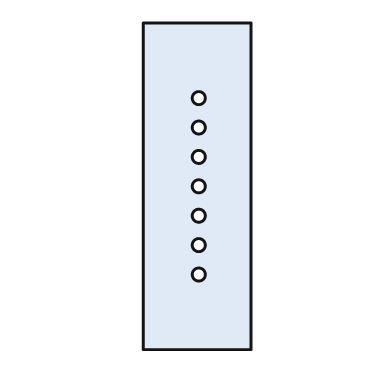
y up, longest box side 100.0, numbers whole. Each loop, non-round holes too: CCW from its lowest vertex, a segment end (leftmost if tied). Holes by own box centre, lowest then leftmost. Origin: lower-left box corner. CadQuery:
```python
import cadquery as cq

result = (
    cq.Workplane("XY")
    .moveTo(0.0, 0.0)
    .lineTo(33.0, 0.0)
    .lineTo(33.0, 100.0)
    .lineTo(0.0, 100.0)
    .close()
    .moveTo(17.0, 23.0)
    .circle(2.0)
    .moveTo(17.0, 32.0)
    .circle(2.0)
    .moveTo(17.0, 41.0)
    .circle(2.0)
    .moveTo(17.0, 50.0)
    .circle(2.0)
    .moveTo(17.0, 59.0)
    .circle(2.0)
    .moveTo(17.0, 68.0)
    .circle(2.0)
    .moveTo(17.0, 77.0)
    .circle(2.0)
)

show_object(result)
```